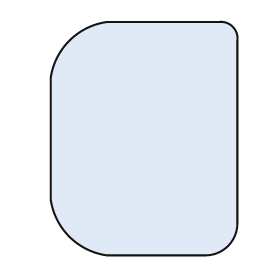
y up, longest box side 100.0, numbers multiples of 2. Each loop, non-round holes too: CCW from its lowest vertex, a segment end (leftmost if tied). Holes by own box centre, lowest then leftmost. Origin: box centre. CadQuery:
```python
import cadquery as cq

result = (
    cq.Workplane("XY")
    .moveTo(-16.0, -50.0)
    .lineTo(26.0, -50.0)
    .threePointArc((36.0, -46.0), (40.0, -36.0))
    .lineTo(40.0, 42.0)
    .threePointArc((38.0, 48.0), (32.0, 50.0))
    .lineTo(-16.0, 50.0)
    .threePointArc((-32.0, 42.0), (-40.0, 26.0))
    .lineTo(-40.0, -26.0)
    .threePointArc((-32.0, -42.0), (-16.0, -50.0))
    .close()
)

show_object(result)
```